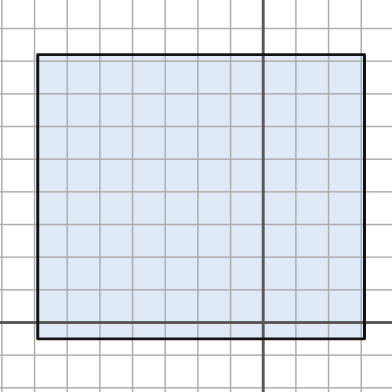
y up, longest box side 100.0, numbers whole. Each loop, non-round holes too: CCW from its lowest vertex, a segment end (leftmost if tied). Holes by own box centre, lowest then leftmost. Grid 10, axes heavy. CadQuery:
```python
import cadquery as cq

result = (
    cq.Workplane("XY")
    .moveTo(-69.0, -5.0)
    .lineTo(31.0, -5.0)
    .lineTo(31.0, 82.0)
    .lineTo(-69.0, 82.0)
    .close()
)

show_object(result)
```